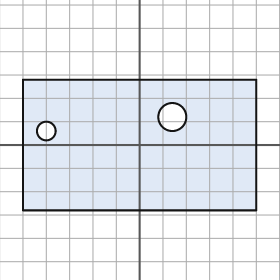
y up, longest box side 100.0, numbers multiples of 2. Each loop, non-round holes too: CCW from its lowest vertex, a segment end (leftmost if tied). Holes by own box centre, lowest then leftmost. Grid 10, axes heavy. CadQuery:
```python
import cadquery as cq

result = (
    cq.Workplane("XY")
    .moveTo(-50.0, -28.0)
    .lineTo(50.0, -28.0)
    .lineTo(50.0, 28.0)
    .lineTo(-50.0, 28.0)
    .close()
    .moveTo(-40.0, 6.0)
    .circle(4.0)
    .moveTo(14.0, 12.0)
    .circle(6.0)
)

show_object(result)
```